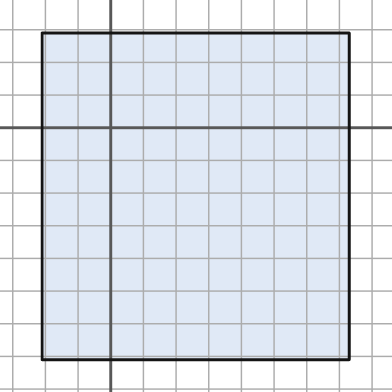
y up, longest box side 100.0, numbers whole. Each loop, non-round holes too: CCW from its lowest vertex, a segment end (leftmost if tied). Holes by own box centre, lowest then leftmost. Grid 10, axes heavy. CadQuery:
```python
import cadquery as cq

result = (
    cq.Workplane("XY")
    .moveTo(-21.0, -71.0)
    .lineTo(73.0, -71.0)
    .lineTo(73.0, 29.0)
    .lineTo(-21.0, 29.0)
    .close()
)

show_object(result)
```